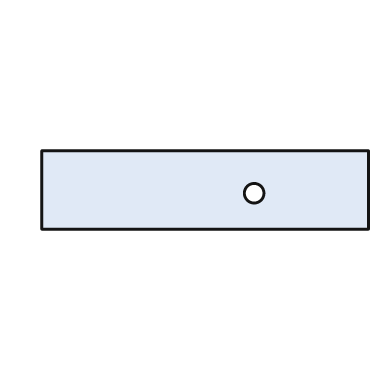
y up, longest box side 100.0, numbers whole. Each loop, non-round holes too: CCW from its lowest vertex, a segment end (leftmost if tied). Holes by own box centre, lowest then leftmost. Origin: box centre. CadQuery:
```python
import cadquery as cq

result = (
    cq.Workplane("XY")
    .moveTo(-50.0, -12.0)
    .lineTo(50.0, -12.0)
    .lineTo(50.0, 12.0)
    .lineTo(-50.0, 12.0)
    .close()
    .moveTo(15.0, -1.0)
    .circle(3.0)
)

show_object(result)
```